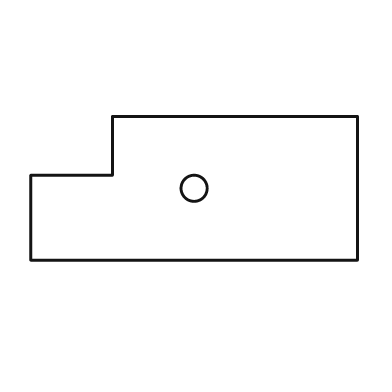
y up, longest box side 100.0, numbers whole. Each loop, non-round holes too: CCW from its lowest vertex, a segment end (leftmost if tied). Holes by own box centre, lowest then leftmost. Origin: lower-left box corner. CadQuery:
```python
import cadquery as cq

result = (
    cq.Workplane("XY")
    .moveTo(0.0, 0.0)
    .lineTo(100.0, 0.0)
    .lineTo(100.0, 44.0)
    .lineTo(25.0, 44.0)
    .lineTo(25.0, 26.0)
    .lineTo(0.0, 26.0)
    .close()
    .moveTo(50.0, 22.0)
    .circle(4.0)
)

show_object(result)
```